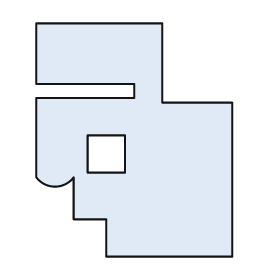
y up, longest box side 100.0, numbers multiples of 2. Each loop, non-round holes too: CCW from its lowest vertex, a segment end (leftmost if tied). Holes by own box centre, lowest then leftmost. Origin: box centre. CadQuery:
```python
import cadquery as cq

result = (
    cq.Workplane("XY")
    .moveTo(-12.0, -50.0)
    .lineTo(42.0, -50.0)
    .lineTo(42.0, 16.0)
    .lineTo(12.0, 16.0)
    .lineTo(12.0, 50.0)
    .lineTo(-42.0, 50.0)
    .lineTo(-42.0, 24.0)
    .lineTo(0.0, 24.0)
    .lineTo(0.0, 18.0)
    .lineTo(-42.0, 18.0)
    .lineTo(-42.0, -16.0)
    .threePointArc((-34.0, -20.0), (-26.0, -16.0))
    .lineTo(-26.0, -34.0)
    .lineTo(-12.0, -34.0)
    .close()
    .moveTo(-20.0, -14.0)
    .lineTo(-4.0, -14.0)
    .lineTo(-4.0, 2.0)
    .lineTo(-20.0, 2.0)
    .close()
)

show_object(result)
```